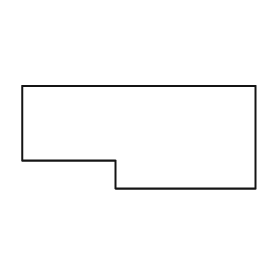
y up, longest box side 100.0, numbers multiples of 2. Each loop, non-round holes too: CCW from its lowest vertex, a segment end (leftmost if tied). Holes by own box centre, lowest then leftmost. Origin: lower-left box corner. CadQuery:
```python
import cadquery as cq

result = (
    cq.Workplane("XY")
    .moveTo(40.0, 0.0)
    .lineTo(100.0, 0.0)
    .lineTo(100.0, 44.0)
    .lineTo(0.0, 44.0)
    .lineTo(0.0, 12.0)
    .lineTo(40.0, 12.0)
    .close()
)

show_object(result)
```